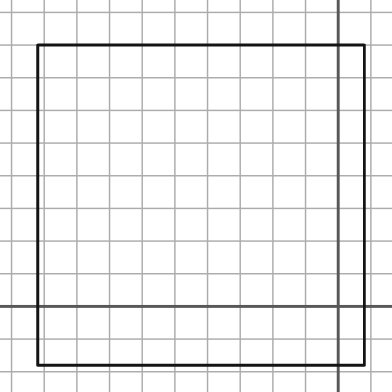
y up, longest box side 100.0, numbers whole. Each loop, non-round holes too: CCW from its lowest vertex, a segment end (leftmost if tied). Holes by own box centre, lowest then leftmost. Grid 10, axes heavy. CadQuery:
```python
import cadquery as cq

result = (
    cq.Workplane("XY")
    .moveTo(-92.0, -18.0)
    .lineTo(8.0, -18.0)
    .lineTo(8.0, 80.0)
    .lineTo(-92.0, 80.0)
    .close()
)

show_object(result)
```